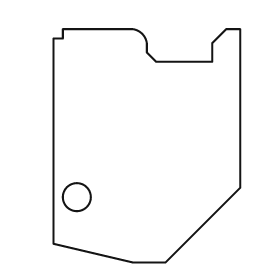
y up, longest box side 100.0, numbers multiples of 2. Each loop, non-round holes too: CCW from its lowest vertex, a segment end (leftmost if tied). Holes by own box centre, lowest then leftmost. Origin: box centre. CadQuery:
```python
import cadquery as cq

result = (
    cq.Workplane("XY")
    .moveTo(-6.0, -50.0)
    .lineTo(8.0, -50.0)
    .lineTo(40.0, -18.0)
    .lineTo(40.0, 50.0)
    .lineTo(34.0, 50.0)
    .lineTo(28.0, 44.0)
    .lineTo(28.0, 36.0)
    .lineTo(4.0, 36.0)
    .lineTo(0.0, 40.0)
    .lineTo(0.0, 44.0)
    .threePointArc((-2.0, 48.0), (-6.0, 50.0))
    .lineTo(-36.0, 50.0)
    .lineTo(-36.0, 46.0)
    .lineTo(-40.0, 46.0)
    .lineTo(-40.0, -42.0)
    .close()
    .moveTo(-30.0, -22.0)
    .circle(6.0)
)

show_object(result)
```